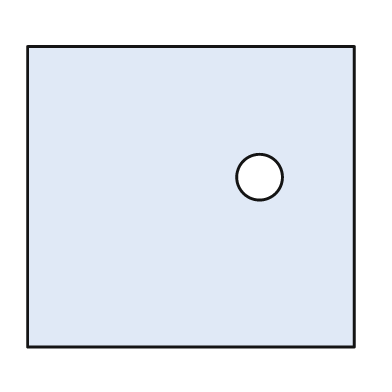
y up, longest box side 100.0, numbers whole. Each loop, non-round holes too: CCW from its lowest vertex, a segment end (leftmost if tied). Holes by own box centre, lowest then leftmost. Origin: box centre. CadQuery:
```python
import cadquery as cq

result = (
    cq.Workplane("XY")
    .moveTo(-50.0, -46.0)
    .lineTo(50.0, -46.0)
    .lineTo(50.0, 46.0)
    .lineTo(-50.0, 46.0)
    .close()
    .moveTo(21.0, 6.0)
    .circle(7.0)
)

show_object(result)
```